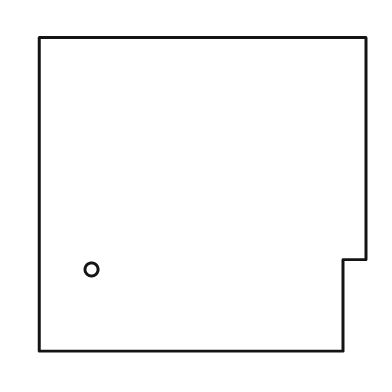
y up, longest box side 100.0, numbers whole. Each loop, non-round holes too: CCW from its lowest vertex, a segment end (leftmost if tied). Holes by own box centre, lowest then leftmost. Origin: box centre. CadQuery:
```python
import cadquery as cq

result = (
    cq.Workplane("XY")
    .moveTo(-50.0, -48.0)
    .lineTo(43.0, -48.0)
    .lineTo(43.0, -20.0)
    .lineTo(50.0, -20.0)
    .lineTo(50.0, 48.0)
    .lineTo(-50.0, 48.0)
    .close()
    .moveTo(-34.0, -23.0)
    .circle(2.0)
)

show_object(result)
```